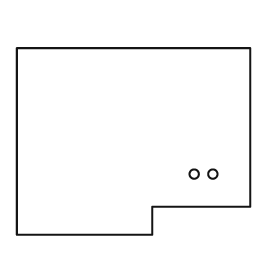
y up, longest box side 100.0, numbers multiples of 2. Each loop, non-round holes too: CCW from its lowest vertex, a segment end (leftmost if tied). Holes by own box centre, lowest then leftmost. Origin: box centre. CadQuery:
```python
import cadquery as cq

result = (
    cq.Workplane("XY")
    .moveTo(-50.0, -40.0)
    .lineTo(8.0, -40.0)
    .lineTo(8.0, -28.0)
    .lineTo(50.0, -28.0)
    .lineTo(50.0, 40.0)
    .lineTo(-50.0, 40.0)
    .close()
    .moveTo(26.0, -14.0)
    .circle(2.0)
    .moveTo(34.0, -14.0)
    .circle(2.0)
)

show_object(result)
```